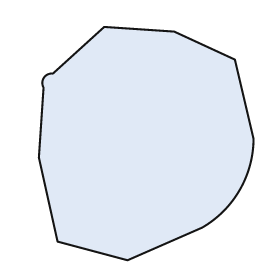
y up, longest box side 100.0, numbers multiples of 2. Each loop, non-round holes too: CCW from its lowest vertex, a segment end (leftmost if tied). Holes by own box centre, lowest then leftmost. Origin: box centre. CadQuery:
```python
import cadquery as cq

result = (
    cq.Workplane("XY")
    .moveTo(-8.0, -50.0)
    .lineTo(24.0, -36.0)
    .threePointArc((40.0, -20.0), (46.0, 2.0))
    .lineTo(38.0, 36.0)
    .lineTo(12.0, 48.0)
    .lineTo(-18.0, 50.0)
    .lineTo(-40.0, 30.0)
    .threePointArc((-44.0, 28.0), (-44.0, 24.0))
    .lineTo(-46.0, -6.0)
    .lineTo(-38.0, -42.0)
    .close()
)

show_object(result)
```